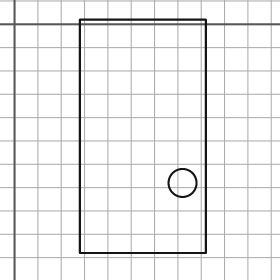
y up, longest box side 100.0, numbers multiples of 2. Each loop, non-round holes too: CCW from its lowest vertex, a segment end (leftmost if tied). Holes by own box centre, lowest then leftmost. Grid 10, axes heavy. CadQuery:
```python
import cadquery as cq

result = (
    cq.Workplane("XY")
    .moveTo(28.0, -98.0)
    .lineTo(82.0, -98.0)
    .lineTo(82.0, 2.0)
    .lineTo(28.0, 2.0)
    .close()
    .moveTo(72.0, -68.0)
    .circle(6.0)
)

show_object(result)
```